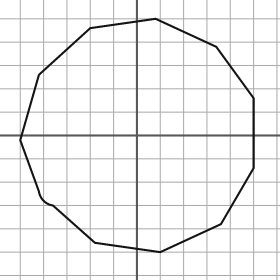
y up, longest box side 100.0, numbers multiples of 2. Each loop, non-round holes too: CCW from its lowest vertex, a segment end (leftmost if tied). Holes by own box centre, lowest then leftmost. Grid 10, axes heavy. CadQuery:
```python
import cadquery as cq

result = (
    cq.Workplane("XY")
    .moveTo(10.0, -50.0)
    .lineTo(36.0, -38.0)
    .lineTo(50.0, -14.0)
    .lineTo(50.0, 16.0)
    .lineTo(34.0, 38.0)
    .lineTo(8.0, 50.0)
    .lineTo(-20.0, 46.0)
    .lineTo(-42.0, 26.0)
    .lineTo(-50.0, -2.0)
    .lineTo(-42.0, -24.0)
    .threePointArc((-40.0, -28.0), (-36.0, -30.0))
    .lineTo(-18.0, -46.0)
    .close()
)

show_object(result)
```